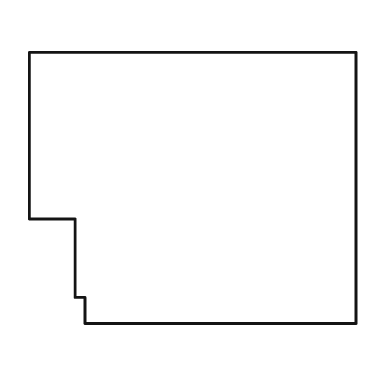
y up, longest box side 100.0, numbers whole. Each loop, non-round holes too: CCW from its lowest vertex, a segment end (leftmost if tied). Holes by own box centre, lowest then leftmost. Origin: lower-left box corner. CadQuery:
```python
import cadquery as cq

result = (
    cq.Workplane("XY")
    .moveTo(17.0, 0.0)
    .lineTo(100.0, 0.0)
    .lineTo(100.0, 83.0)
    .lineTo(0.0, 83.0)
    .lineTo(0.0, 32.0)
    .lineTo(14.0, 32.0)
    .lineTo(14.0, 8.0)
    .lineTo(17.0, 8.0)
    .close()
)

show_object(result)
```